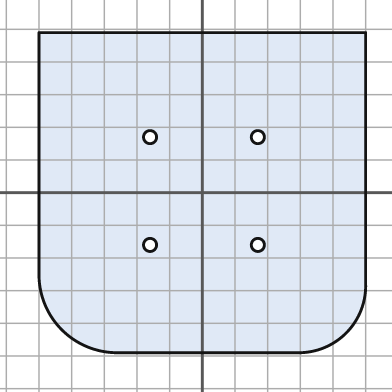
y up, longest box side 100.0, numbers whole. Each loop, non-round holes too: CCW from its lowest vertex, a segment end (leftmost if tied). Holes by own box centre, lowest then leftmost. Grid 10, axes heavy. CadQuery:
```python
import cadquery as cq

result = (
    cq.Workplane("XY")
    .moveTo(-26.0, -49.0)
    .lineTo(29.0, -49.0)
    .threePointArc((44.0, -43.0), (50.0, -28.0))
    .lineTo(50.0, 49.0)
    .lineTo(-50.0, 49.0)
    .lineTo(-50.0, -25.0)
    .threePointArc((-43.0, -42.0), (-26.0, -49.0))
    .close()
    .moveTo(-16.0, -16.0)
    .circle(2.0)
    .moveTo(17.0, -16.0)
    .circle(2.0)
    .moveTo(-16.0, 17.0)
    .circle(2.0)
    .moveTo(17.0, 17.0)
    .circle(2.0)
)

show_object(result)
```